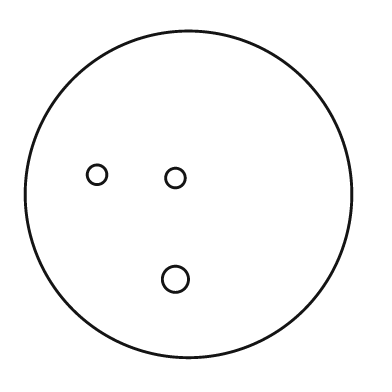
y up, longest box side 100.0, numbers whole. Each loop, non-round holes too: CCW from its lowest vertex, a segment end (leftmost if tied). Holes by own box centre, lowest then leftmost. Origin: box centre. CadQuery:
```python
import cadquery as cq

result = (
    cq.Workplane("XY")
    .moveTo(0.0, 0.0)
    .circle(50.0)
    .moveTo(-4.0, -26.0)
    .circle(4.0)
    .moveTo(-4.0, 5.0)
    .circle(3.0)
    .moveTo(-28.0, 6.0)
    .circle(3.0)
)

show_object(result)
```